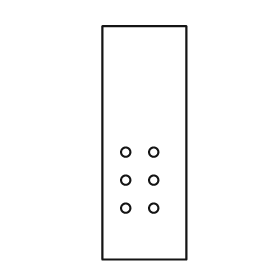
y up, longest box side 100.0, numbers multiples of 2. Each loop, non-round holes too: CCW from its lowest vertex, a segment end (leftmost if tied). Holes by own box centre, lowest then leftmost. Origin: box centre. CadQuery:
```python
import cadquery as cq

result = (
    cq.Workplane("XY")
    .moveTo(-18.0, -50.0)
    .lineTo(18.0, -50.0)
    .lineTo(18.0, 50.0)
    .lineTo(-18.0, 50.0)
    .close()
    .moveTo(-8.0, -28.0)
    .circle(2.0)
    .moveTo(4.0, -28.0)
    .circle(2.0)
    .moveTo(-8.0, -16.0)
    .circle(2.0)
    .moveTo(4.0, -16.0)
    .circle(2.0)
    .moveTo(-8.0, -4.0)
    .circle(2.0)
    .moveTo(4.0, -4.0)
    .circle(2.0)
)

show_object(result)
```